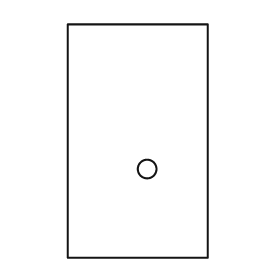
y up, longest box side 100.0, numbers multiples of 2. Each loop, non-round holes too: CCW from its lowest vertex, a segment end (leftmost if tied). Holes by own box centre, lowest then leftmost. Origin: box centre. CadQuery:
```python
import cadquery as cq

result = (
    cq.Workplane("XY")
    .moveTo(-30.0, -50.0)
    .lineTo(30.0, -50.0)
    .lineTo(30.0, 50.0)
    .lineTo(-30.0, 50.0)
    .close()
    .moveTo(4.0, -12.0)
    .circle(4.0)
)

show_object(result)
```